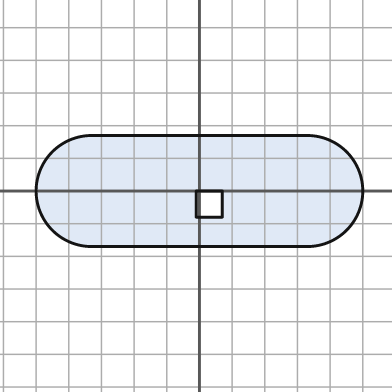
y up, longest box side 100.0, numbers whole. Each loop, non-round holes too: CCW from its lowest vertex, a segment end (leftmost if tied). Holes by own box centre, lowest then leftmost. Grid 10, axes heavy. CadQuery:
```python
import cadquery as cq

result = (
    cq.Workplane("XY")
    .moveTo(-33.0, -17.0)
    .lineTo(33.0, -17.0)
    .threePointArc((50.0, 0.0), (33.0, 17.0))
    .lineTo(-33.0, 17.0)
    .threePointArc((-50.0, 0.0), (-33.0, -17.0))
    .close()
    .moveTo(-1.0, -8.0)
    .lineTo(7.0, -8.0)
    .lineTo(7.0, 0.0)
    .lineTo(-1.0, 0.0)
    .close()
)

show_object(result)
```